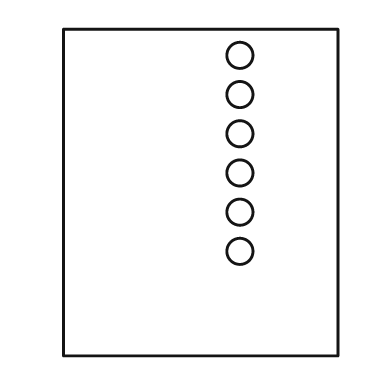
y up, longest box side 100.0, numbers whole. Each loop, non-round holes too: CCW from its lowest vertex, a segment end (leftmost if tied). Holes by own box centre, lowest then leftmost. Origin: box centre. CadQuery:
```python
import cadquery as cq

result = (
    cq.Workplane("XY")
    .moveTo(-42.0, -50.0)
    .lineTo(42.0, -50.0)
    .lineTo(42.0, 50.0)
    .lineTo(-42.0, 50.0)
    .close()
    .moveTo(12.0, -18.0)
    .circle(4.0)
    .moveTo(12.0, -6.0)
    .circle(4.0)
    .moveTo(12.0, 6.0)
    .circle(4.0)
    .moveTo(12.0, 18.0)
    .circle(4.0)
    .moveTo(12.0, 30.0)
    .circle(4.0)
    .moveTo(12.0, 42.0)
    .circle(4.0)
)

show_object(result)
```